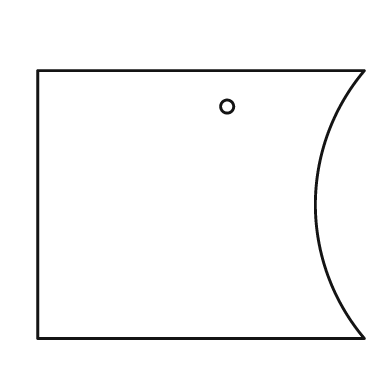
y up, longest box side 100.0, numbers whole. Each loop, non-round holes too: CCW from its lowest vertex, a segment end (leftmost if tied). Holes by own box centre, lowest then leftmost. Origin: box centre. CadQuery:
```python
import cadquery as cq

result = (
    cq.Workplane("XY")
    .moveTo(-50.0, -41.0)
    .lineTo(50.0, -41.0)
    .threePointArc((35.0, 0.0), (50.0, 41.0))
    .lineTo(-50.0, 41.0)
    .close()
    .moveTo(8.0, 30.0)
    .circle(2.0)
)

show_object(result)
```